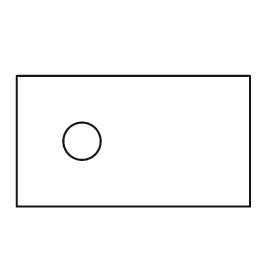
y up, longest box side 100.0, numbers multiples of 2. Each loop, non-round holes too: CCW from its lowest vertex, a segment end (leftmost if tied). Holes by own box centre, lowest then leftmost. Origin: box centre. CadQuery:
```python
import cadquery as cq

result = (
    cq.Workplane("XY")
    .moveTo(-50.0, -28.0)
    .lineTo(50.0, -28.0)
    .lineTo(50.0, 28.0)
    .lineTo(-50.0, 28.0)
    .close()
    .moveTo(-22.0, 0.0)
    .circle(8.0)
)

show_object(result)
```